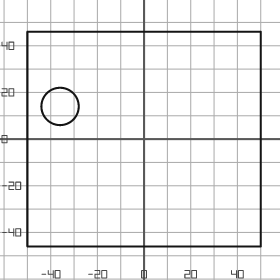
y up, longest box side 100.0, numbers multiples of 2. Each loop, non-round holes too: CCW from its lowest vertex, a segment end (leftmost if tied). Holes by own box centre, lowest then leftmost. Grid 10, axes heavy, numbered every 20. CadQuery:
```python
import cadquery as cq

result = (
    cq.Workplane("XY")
    .moveTo(-50.0, -46.0)
    .lineTo(50.0, -46.0)
    .lineTo(50.0, 46.0)
    .lineTo(-50.0, 46.0)
    .close()
    .moveTo(-36.0, 14.0)
    .circle(8.0)
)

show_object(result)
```